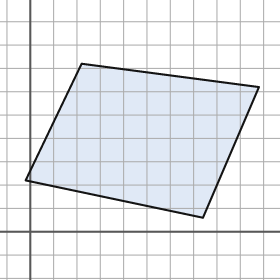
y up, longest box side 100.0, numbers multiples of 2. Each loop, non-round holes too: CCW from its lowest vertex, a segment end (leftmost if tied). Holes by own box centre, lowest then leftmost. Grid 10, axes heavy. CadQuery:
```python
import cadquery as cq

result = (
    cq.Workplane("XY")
    .moveTo(74.0, 6.0)
    .lineTo(98.0, 62.0)
    .lineTo(22.0, 72.0)
    .lineTo(-2.0, 22.0)
    .close()
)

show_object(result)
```